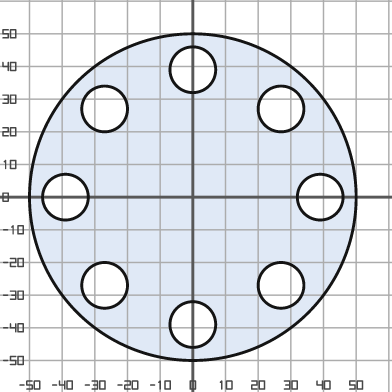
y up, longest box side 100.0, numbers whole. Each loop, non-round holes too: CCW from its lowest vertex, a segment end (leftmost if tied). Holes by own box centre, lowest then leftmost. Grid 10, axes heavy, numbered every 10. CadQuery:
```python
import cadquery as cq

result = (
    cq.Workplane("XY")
    .moveTo(0.0, 0.0)
    .circle(50.0)
    .moveTo(0.0, -39.0)
    .circle(7.0)
    .moveTo(-27.0, -27.0)
    .circle(7.0)
    .moveTo(27.0, -27.0)
    .circle(7.0)
    .moveTo(-39.0, 0.0)
    .circle(7.0)
    .moveTo(39.0, 0.0)
    .circle(7.0)
    .moveTo(-27.0, 27.0)
    .circle(7.0)
    .moveTo(27.0, 27.0)
    .circle(7.0)
    .moveTo(0.0, 39.0)
    .circle(7.0)
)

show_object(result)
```